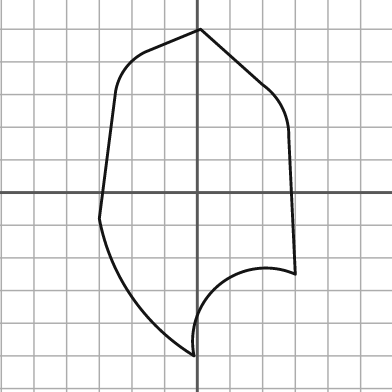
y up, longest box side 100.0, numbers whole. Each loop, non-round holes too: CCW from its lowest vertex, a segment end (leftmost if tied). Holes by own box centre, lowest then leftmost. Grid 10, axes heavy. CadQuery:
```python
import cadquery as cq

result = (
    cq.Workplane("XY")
    .moveTo(-1.0, -50.0)
    .threePointArc((7.0, -28.0), (30.0, -25.0))
    .lineTo(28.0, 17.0)
    .threePointArc((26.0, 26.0), (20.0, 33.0))
    .lineTo(1.0, 50.0)
    .lineTo(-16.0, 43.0)
    .threePointArc((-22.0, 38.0), (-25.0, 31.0))
    .lineTo(-30.0, -8.0)
    .threePointArc((-20.0, -32.0), (-1.0, -50.0))
    .close()
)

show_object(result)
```